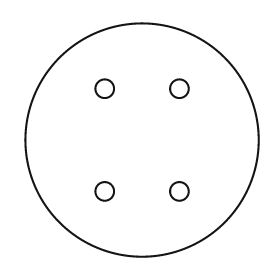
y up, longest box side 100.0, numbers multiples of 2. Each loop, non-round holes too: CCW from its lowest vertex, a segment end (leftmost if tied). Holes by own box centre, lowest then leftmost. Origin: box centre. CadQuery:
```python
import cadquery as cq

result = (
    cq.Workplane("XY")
    .moveTo(0.0, 0.0)
    .circle(50.0)
    .moveTo(-16.0, -22.0)
    .circle(4.0)
    .moveTo(16.0, -22.0)
    .circle(4.0)
    .moveTo(-16.0, 22.0)
    .circle(4.0)
    .moveTo(16.0, 22.0)
    .circle(4.0)
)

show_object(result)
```